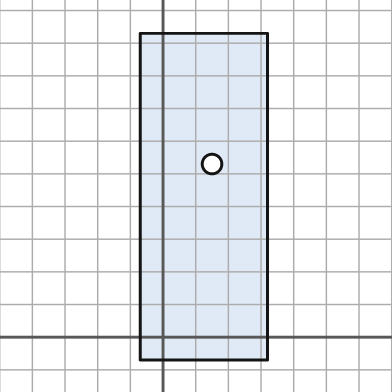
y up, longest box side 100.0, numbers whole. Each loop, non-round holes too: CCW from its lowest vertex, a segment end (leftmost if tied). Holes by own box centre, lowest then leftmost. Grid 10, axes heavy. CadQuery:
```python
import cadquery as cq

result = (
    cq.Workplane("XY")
    .moveTo(-7.0, -7.0)
    .lineTo(32.0, -7.0)
    .lineTo(32.0, 93.0)
    .lineTo(-7.0, 93.0)
    .close()
    .moveTo(15.0, 53.0)
    .circle(3.0)
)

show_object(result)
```